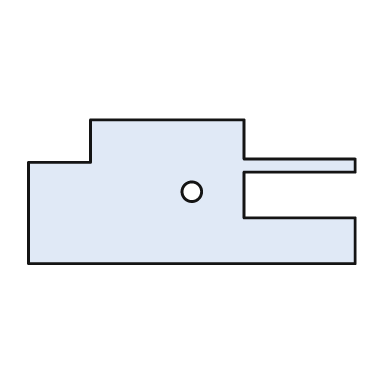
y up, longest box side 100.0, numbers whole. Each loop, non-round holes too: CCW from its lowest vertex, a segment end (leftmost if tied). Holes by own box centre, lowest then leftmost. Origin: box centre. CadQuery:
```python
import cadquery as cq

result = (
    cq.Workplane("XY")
    .moveTo(-50.0, -22.0)
    .lineTo(50.0, -22.0)
    .lineTo(50.0, -8.0)
    .lineTo(16.0, -8.0)
    .lineTo(16.0, 6.0)
    .lineTo(50.0, 6.0)
    .lineTo(50.0, 10.0)
    .lineTo(16.0, 10.0)
    .lineTo(16.0, 22.0)
    .lineTo(-31.0, 22.0)
    .lineTo(-31.0, 9.0)
    .lineTo(-50.0, 9.0)
    .close()
    .moveTo(0.0, 0.0)
    .circle(3.0)
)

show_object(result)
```